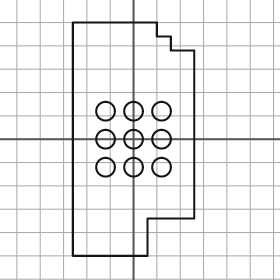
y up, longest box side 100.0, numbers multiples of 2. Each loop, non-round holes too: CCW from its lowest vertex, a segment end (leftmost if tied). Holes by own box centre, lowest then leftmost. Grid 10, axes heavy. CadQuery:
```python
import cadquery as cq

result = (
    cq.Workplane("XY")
    .moveTo(-26.0, -50.0)
    .lineTo(6.0, -50.0)
    .lineTo(6.0, -34.0)
    .lineTo(26.0, -34.0)
    .lineTo(26.0, 38.0)
    .lineTo(16.0, 38.0)
    .lineTo(16.0, 44.0)
    .lineTo(10.0, 44.0)
    .lineTo(10.0, 50.0)
    .lineTo(-26.0, 50.0)
    .close()
    .moveTo(-12.0, -12.0)
    .circle(4.0)
    .moveTo(0.0, -12.0)
    .circle(4.0)
    .moveTo(12.0, -12.0)
    .circle(4.0)
    .moveTo(-12.0, 0.0)
    .circle(4.0)
    .moveTo(0.0, 0.0)
    .circle(4.0)
    .moveTo(12.0, 0.0)
    .circle(4.0)
    .moveTo(-12.0, 12.0)
    .circle(4.0)
    .moveTo(0.0, 12.0)
    .circle(4.0)
    .moveTo(12.0, 12.0)
    .circle(4.0)
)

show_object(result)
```